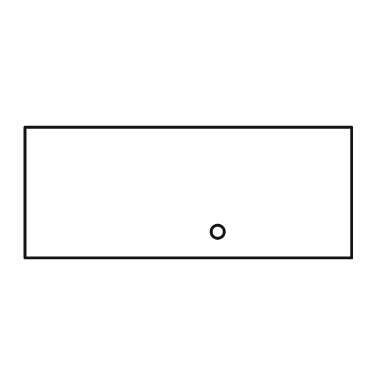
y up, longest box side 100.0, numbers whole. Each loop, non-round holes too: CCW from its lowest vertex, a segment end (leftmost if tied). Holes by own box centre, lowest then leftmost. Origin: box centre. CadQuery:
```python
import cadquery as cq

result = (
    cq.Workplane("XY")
    .moveTo(-50.0, -20.0)
    .lineTo(50.0, -20.0)
    .lineTo(50.0, 20.0)
    .lineTo(-50.0, 20.0)
    .close()
    .moveTo(9.0, -12.0)
    .circle(2.0)
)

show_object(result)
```